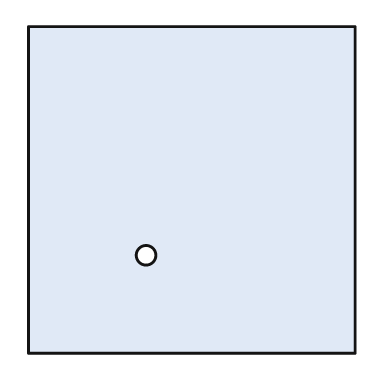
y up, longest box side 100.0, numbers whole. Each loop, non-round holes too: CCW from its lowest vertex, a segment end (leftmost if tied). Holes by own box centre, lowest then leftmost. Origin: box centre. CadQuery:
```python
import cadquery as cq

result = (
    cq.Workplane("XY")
    .moveTo(-50.0, -50.0)
    .lineTo(50.0, -50.0)
    .lineTo(50.0, 50.0)
    .lineTo(-50.0, 50.0)
    .close()
    .moveTo(-14.0, -20.0)
    .circle(3.0)
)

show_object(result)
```